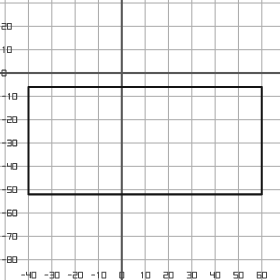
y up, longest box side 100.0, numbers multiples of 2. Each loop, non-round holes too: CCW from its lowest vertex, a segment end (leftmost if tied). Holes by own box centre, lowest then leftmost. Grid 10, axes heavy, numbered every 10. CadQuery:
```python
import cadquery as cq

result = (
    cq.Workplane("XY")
    .moveTo(-40.0, -52.0)
    .lineTo(60.0, -52.0)
    .lineTo(60.0, -6.0)
    .lineTo(-40.0, -6.0)
    .close()
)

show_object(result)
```